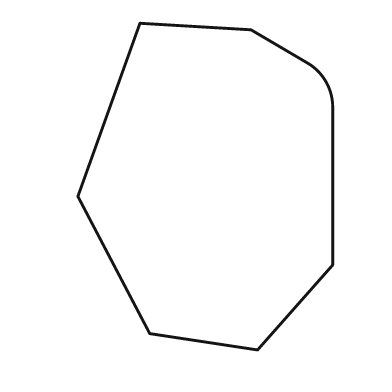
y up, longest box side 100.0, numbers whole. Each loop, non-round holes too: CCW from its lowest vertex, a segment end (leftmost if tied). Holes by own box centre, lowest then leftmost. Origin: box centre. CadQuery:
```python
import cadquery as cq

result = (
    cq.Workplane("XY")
    .moveTo(16.0, -50.0)
    .lineTo(39.0, -24.0)
    .lineTo(39.0, 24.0)
    .threePointArc((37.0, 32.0), (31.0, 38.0))
    .lineTo(14.0, 48.0)
    .lineTo(-20.0, 50.0)
    .lineTo(-39.0, -3.0)
    .lineTo(-17.0, -45.0)
    .close()
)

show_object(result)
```